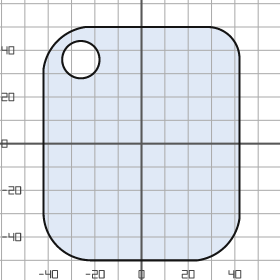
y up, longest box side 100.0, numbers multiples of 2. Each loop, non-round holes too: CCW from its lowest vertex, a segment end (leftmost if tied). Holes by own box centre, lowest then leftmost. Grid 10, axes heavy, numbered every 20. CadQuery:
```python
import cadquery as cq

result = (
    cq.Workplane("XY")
    .moveTo(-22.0, -50.0)
    .lineTo(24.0, -50.0)
    .threePointArc((36.0, -44.0), (42.0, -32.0))
    .lineTo(42.0, 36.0)
    .threePointArc((38.0, 46.0), (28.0, 50.0))
    .lineTo(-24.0, 50.0)
    .threePointArc((-36.0, 44.0), (-42.0, 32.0))
    .lineTo(-42.0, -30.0)
    .threePointArc((-36.0, -44.0), (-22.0, -50.0))
    .close()
    .moveTo(-26.0, 36.0)
    .circle(8.0)
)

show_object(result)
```